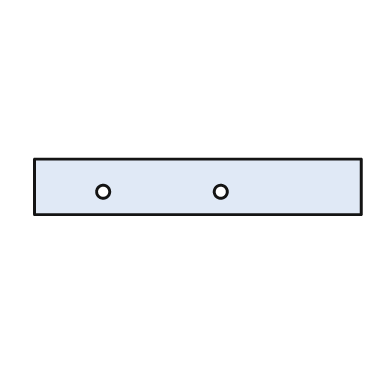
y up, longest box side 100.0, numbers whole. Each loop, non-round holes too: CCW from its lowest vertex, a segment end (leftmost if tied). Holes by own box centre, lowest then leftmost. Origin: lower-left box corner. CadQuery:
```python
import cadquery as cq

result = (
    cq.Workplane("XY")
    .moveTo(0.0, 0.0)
    .lineTo(100.0, 0.0)
    .lineTo(100.0, 17.0)
    .lineTo(0.0, 17.0)
    .close()
    .moveTo(21.0, 7.0)
    .circle(2.0)
    .moveTo(57.0, 7.0)
    .circle(2.0)
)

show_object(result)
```